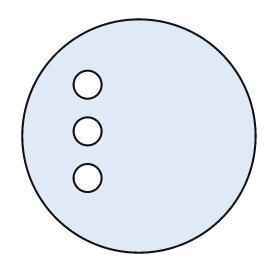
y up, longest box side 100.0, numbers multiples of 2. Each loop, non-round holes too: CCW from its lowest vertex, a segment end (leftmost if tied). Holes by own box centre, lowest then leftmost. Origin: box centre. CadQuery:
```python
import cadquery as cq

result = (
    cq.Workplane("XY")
    .moveTo(0.0, 0.0)
    .circle(50.0)
    .moveTo(-22.0, -18.0)
    .circle(6.0)
    .moveTo(-22.0, 2.0)
    .circle(6.0)
    .moveTo(-22.0, 22.0)
    .circle(6.0)
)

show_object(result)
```